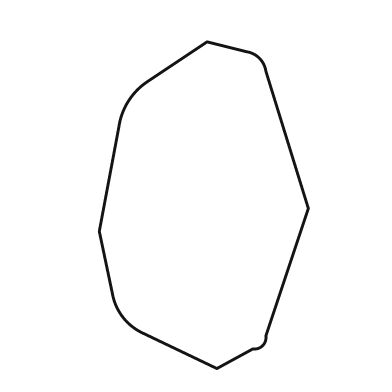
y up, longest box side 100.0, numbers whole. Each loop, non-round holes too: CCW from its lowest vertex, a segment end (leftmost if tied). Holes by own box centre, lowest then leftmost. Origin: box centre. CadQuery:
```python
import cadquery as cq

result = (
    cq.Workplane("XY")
    .moveTo(4.0, -50.0)
    .lineTo(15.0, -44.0)
    .threePointArc((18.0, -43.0), (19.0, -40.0))
    .lineTo(32.0, -1.0)
    .lineTo(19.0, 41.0)
    .threePointArc((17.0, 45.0), (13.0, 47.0))
    .lineTo(1.0, 50.0)
    .lineTo(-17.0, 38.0)
    .threePointArc((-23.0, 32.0), (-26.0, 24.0))
    .lineTo(-32.0, -8.0)
    .lineTo(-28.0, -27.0)
    .threePointArc((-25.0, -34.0), (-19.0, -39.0))
    .close()
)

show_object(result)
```